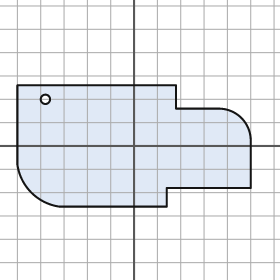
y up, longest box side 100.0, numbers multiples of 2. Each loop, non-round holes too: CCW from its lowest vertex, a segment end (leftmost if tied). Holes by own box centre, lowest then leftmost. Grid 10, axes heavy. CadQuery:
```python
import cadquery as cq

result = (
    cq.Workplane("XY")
    .moveTo(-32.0, -26.0)
    .lineTo(14.0, -26.0)
    .lineTo(14.0, -18.0)
    .lineTo(50.0, -18.0)
    .lineTo(50.0, 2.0)
    .threePointArc((46.0, 12.0), (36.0, 16.0))
    .lineTo(18.0, 16.0)
    .lineTo(18.0, 26.0)
    .lineTo(-50.0, 26.0)
    .lineTo(-50.0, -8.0)
    .threePointArc((-44.0, -20.0), (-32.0, -26.0))
    .close()
    .moveTo(-38.0, 20.0)
    .circle(2.0)
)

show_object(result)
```